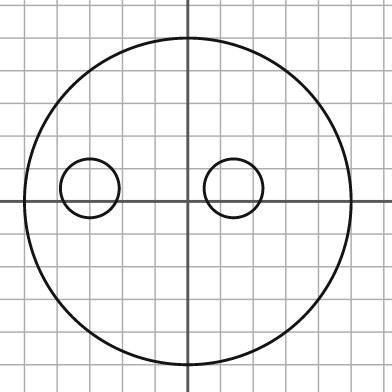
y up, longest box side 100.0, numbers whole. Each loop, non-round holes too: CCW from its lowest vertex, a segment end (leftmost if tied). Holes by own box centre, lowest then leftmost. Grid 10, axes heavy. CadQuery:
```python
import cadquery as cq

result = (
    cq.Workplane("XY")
    .moveTo(0.0, 0.0)
    .circle(50.0)
    .moveTo(-30.0, 4.0)
    .circle(9.0)
    .moveTo(14.0, 4.0)
    .circle(9.0)
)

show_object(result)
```